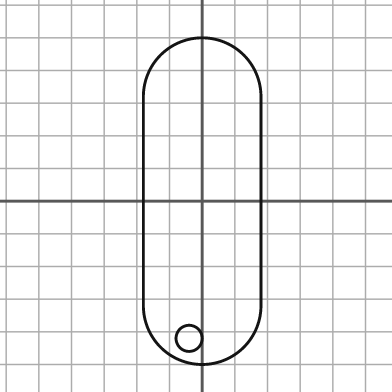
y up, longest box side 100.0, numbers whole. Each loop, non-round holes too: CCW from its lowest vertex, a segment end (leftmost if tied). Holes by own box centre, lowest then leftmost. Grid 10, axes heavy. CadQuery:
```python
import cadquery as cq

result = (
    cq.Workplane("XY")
    .moveTo(-18.0, -32.0)
    .threePointArc((0.0, -50.0), (18.0, -32.0))
    .lineTo(18.0, 32.0)
    .threePointArc((0.0, 50.0), (-18.0, 32.0))
    .close()
    .moveTo(-4.0, -42.0)
    .circle(4.0)
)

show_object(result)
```